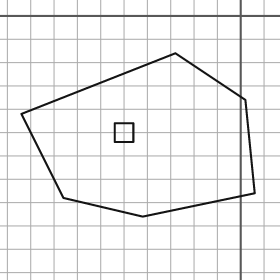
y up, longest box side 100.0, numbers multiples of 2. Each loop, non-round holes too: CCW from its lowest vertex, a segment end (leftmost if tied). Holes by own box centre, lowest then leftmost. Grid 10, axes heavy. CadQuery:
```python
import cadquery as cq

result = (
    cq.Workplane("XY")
    .moveTo(-42.0, -86.0)
    .lineTo(6.0, -76.0)
    .lineTo(2.0, -36.0)
    .lineTo(-28.0, -16.0)
    .lineTo(-94.0, -42.0)
    .lineTo(-76.0, -78.0)
    .close()
    .moveTo(-54.0, -54.0)
    .lineTo(-46.0, -54.0)
    .lineTo(-46.0, -46.0)
    .lineTo(-54.0, -46.0)
    .close()
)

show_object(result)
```